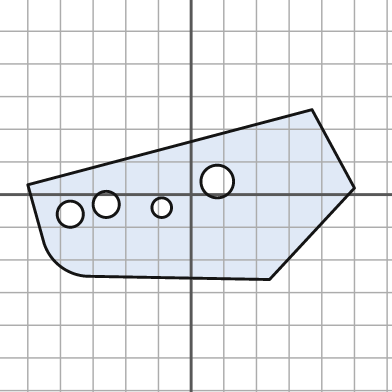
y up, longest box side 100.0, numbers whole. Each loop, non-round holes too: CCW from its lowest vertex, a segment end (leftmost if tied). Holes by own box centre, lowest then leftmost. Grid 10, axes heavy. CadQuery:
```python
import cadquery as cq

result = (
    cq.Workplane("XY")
    .moveTo(24.0, -26.0)
    .lineTo(50.0, 2.0)
    .lineTo(37.0, 26.0)
    .lineTo(-50.0, 3.0)
    .lineTo(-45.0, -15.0)
    .threePointArc((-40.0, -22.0), (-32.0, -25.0))
    .close()
    .moveTo(-37.0, -6.0)
    .circle(4.0)
    .moveTo(-9.0, -4.0)
    .circle(3.0)
    .moveTo(-26.0, -3.0)
    .circle(4.0)
    .moveTo(8.0, 4.0)
    .circle(5.0)
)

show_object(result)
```